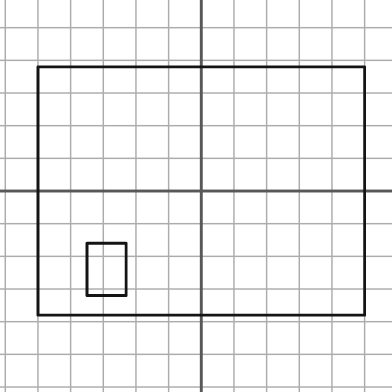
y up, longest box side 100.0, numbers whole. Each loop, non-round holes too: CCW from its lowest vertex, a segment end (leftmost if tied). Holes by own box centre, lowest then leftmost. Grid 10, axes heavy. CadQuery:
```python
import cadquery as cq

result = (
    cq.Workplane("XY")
    .moveTo(-50.0, -38.0)
    .lineTo(50.0, -38.0)
    .lineTo(50.0, 38.0)
    .lineTo(-50.0, 38.0)
    .close()
    .moveTo(-35.0, -32.0)
    .lineTo(-23.0, -32.0)
    .lineTo(-23.0, -16.0)
    .lineTo(-35.0, -16.0)
    .close()
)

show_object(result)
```